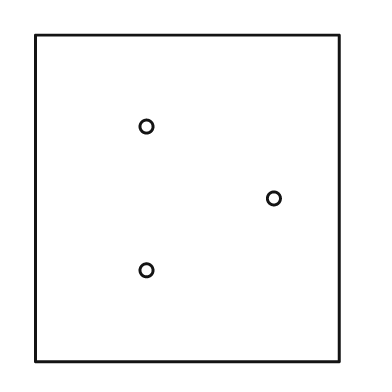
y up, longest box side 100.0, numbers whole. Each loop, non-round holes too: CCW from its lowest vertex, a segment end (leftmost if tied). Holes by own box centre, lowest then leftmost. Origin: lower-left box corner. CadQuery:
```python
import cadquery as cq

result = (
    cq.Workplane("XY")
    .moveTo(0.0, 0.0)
    .lineTo(93.0, 0.0)
    .lineTo(93.0, 100.0)
    .lineTo(0.0, 100.0)
    .close()
    .moveTo(34.0, 28.0)
    .circle(2.0)
    .moveTo(73.0, 50.0)
    .circle(2.0)
    .moveTo(34.0, 72.0)
    .circle(2.0)
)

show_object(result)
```